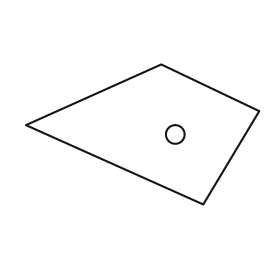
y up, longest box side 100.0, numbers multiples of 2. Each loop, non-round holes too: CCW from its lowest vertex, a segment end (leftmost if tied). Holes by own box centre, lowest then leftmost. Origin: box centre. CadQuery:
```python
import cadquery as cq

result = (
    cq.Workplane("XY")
    .moveTo(26.0, -30.0)
    .lineTo(50.0, 10.0)
    .lineTo(8.0, 30.0)
    .lineTo(-50.0, 4.0)
    .close()
    .moveTo(14.0, 0.0)
    .circle(4.0)
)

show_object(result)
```